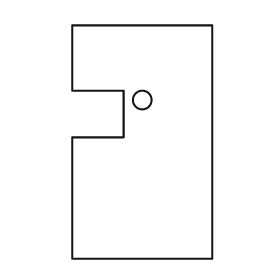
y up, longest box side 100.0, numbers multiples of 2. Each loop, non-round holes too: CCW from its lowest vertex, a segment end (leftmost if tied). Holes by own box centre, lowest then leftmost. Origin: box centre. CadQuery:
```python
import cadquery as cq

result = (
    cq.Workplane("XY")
    .moveTo(-30.0, -50.0)
    .lineTo(30.0, -50.0)
    .lineTo(30.0, 50.0)
    .lineTo(-30.0, 50.0)
    .lineTo(-30.0, 22.0)
    .lineTo(-8.0, 22.0)
    .lineTo(-8.0, 2.0)
    .lineTo(-30.0, 2.0)
    .close()
    .moveTo(0.0, 18.0)
    .circle(4.0)
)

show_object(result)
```